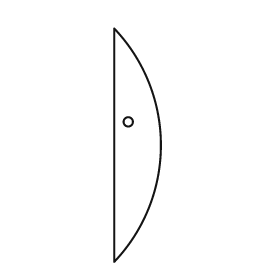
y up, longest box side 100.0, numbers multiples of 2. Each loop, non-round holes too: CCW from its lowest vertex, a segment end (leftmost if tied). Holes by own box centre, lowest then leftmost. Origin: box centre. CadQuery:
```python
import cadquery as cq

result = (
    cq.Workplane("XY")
    .moveTo(-10.0, -50.0)
    .threePointArc((10.0, 0.0), (-10.0, 50.0))
    .close()
    .moveTo(-4.0, 10.0)
    .circle(2.0)
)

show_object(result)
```